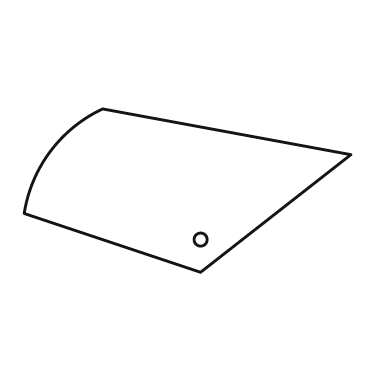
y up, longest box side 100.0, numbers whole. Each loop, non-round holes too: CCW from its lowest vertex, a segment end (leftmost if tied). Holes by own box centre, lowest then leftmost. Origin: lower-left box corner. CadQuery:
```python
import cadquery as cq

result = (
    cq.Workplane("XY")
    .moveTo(54.0, 0.0)
    .lineTo(100.0, 36.0)
    .lineTo(24.0, 50.0)
    .threePointArc((8.0, 37.0), (0.0, 18.0))
    .close()
    .moveTo(54.0, 10.0)
    .circle(2.0)
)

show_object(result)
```